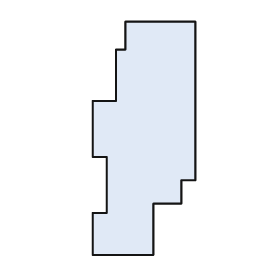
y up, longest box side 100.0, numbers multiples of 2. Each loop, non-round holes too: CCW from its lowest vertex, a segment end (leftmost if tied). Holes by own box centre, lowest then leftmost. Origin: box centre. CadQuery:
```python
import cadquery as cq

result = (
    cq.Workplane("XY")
    .moveTo(-22.0, -50.0)
    .lineTo(4.0, -50.0)
    .lineTo(4.0, -28.0)
    .lineTo(16.0, -28.0)
    .lineTo(16.0, -18.0)
    .lineTo(22.0, -18.0)
    .lineTo(22.0, 50.0)
    .lineTo(-8.0, 50.0)
    .lineTo(-8.0, 38.0)
    .lineTo(-12.0, 38.0)
    .lineTo(-12.0, 16.0)
    .lineTo(-22.0, 16.0)
    .lineTo(-22.0, -8.0)
    .lineTo(-16.0, -8.0)
    .lineTo(-16.0, -32.0)
    .lineTo(-22.0, -32.0)
    .close()
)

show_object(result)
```